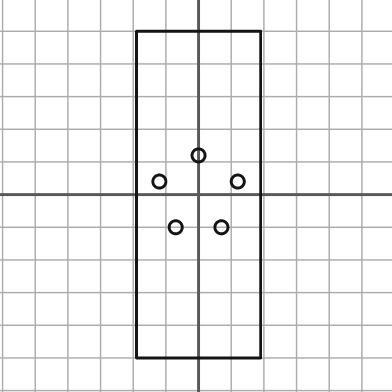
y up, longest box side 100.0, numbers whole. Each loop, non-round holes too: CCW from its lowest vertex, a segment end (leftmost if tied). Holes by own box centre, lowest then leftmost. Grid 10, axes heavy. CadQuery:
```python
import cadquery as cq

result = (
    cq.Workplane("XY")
    .moveTo(-19.0, -50.0)
    .lineTo(19.0, -50.0)
    .lineTo(19.0, 50.0)
    .lineTo(-19.0, 50.0)
    .close()
    .moveTo(-7.0, -10.0)
    .circle(2.0)
    .moveTo(7.0, -10.0)
    .circle(2.0)
    .moveTo(-12.0, 4.0)
    .circle(2.0)
    .moveTo(12.0, 4.0)
    .circle(2.0)
    .moveTo(0.0, 12.0)
    .circle(2.0)
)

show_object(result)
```